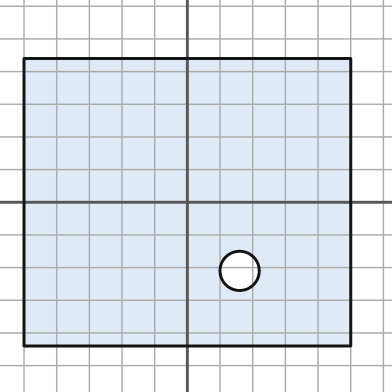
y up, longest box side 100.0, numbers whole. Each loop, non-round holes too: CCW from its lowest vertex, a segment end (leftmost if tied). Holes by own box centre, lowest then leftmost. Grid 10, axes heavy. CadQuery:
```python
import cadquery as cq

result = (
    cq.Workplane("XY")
    .moveTo(-50.0, -44.0)
    .lineTo(50.0, -44.0)
    .lineTo(50.0, 44.0)
    .lineTo(-50.0, 44.0)
    .close()
    .moveTo(16.0, -21.0)
    .circle(6.0)
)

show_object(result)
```